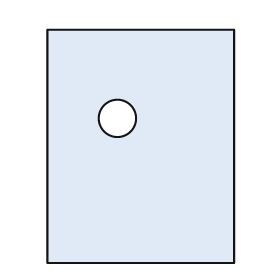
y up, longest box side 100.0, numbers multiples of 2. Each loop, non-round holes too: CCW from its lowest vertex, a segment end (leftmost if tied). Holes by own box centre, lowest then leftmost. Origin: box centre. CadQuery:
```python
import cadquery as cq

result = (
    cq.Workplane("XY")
    .moveTo(-40.0, -50.0)
    .lineTo(40.0, -50.0)
    .lineTo(40.0, 50.0)
    .lineTo(-40.0, 50.0)
    .close()
    .moveTo(-10.0, 12.0)
    .circle(8.0)
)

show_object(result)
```